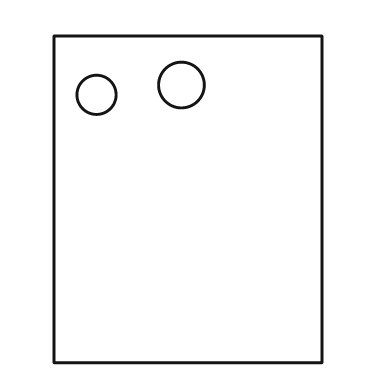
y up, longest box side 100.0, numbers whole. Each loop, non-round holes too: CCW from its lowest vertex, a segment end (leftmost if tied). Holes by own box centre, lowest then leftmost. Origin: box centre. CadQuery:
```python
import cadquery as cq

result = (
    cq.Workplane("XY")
    .moveTo(-41.0, -50.0)
    .lineTo(41.0, -50.0)
    .lineTo(41.0, 50.0)
    .lineTo(-41.0, 50.0)
    .close()
    .moveTo(-28.0, 32.0)
    .circle(6.0)
    .moveTo(-2.0, 35.0)
    .circle(7.0)
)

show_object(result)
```